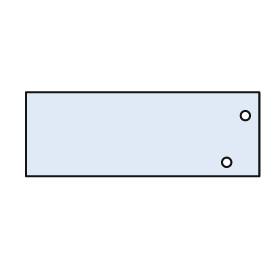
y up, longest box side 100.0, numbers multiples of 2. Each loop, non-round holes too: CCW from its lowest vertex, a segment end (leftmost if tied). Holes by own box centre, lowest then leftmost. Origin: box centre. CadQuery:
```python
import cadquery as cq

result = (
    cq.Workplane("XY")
    .moveTo(-50.0, -18.0)
    .lineTo(50.0, -18.0)
    .lineTo(50.0, 18.0)
    .lineTo(-50.0, 18.0)
    .close()
    .moveTo(36.0, -12.0)
    .circle(2.0)
    .moveTo(44.0, 8.0)
    .circle(2.0)
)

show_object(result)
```